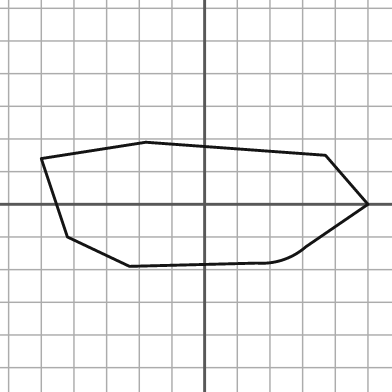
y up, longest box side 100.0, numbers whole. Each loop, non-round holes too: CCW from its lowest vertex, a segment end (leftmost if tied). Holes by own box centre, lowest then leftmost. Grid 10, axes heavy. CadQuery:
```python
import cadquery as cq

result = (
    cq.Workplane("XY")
    .moveTo(-23.0, -19.0)
    .lineTo(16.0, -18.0)
    .threePointArc((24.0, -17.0), (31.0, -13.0))
    .lineTo(50.0, 0.0)
    .lineTo(37.0, 15.0)
    .lineTo(-18.0, 19.0)
    .lineTo(-50.0, 14.0)
    .lineTo(-42.0, -10.0)
    .close()
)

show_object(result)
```